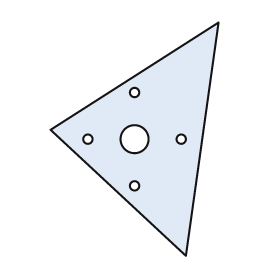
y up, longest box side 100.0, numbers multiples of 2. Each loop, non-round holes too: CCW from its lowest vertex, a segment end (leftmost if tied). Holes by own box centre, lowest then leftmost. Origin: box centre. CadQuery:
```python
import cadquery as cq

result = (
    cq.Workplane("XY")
    .moveTo(22.0, -50.0)
    .lineTo(36.0, 50.0)
    .lineTo(-36.0, 4.0)
    .close()
    .moveTo(0.0, -20.0)
    .circle(2.0)
    .moveTo(-20.0, 0.0)
    .circle(2.0)
    .moveTo(0.0, 0.0)
    .circle(6.0)
    .moveTo(20.0, 0.0)
    .circle(2.0)
    .moveTo(0.0, 20.0)
    .circle(2.0)
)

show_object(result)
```